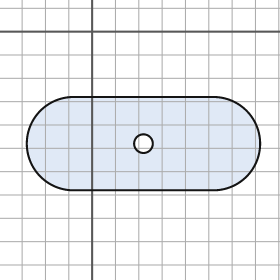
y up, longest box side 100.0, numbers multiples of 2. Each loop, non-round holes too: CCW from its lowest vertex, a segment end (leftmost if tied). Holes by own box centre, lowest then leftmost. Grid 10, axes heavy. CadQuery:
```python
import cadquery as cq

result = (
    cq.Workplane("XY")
    .moveTo(-8.0, -68.0)
    .lineTo(52.0, -68.0)
    .threePointArc((72.0, -48.0), (52.0, -28.0))
    .lineTo(-8.0, -28.0)
    .threePointArc((-28.0, -48.0), (-8.0, -68.0))
    .close()
    .moveTo(22.0, -48.0)
    .circle(4.0)
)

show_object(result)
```